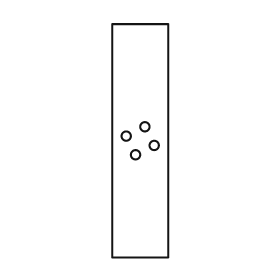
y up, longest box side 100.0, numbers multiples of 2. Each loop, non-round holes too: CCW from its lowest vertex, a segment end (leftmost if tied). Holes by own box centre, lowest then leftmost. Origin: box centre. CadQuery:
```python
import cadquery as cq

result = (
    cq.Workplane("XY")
    .moveTo(-12.0, -50.0)
    .lineTo(12.0, -50.0)
    .lineTo(12.0, 50.0)
    .lineTo(-12.0, 50.0)
    .close()
    .moveTo(-2.0, -6.0)
    .circle(2.0)
    .moveTo(6.0, -2.0)
    .circle(2.0)
    .moveTo(-6.0, 2.0)
    .circle(2.0)
    .moveTo(2.0, 6.0)
    .circle(2.0)
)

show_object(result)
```